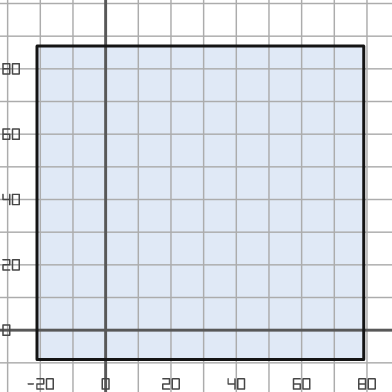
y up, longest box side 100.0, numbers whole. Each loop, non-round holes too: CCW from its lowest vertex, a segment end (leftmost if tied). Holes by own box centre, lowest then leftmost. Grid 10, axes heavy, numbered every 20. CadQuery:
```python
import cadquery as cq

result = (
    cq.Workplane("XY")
    .moveTo(-21.0, -9.0)
    .lineTo(79.0, -9.0)
    .lineTo(79.0, 87.0)
    .lineTo(-21.0, 87.0)
    .close()
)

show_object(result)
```